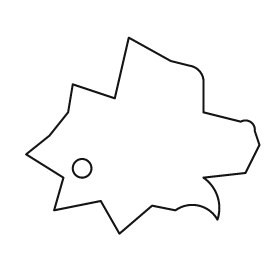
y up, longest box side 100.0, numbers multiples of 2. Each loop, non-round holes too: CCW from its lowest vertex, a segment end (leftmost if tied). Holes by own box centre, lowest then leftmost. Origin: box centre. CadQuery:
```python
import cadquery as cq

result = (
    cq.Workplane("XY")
    .moveTo(-10.0, -42.0)
    .lineTo(4.0, -30.0)
    .lineTo(14.0, -32.0)
    .threePointArc((24.0, -30.0), (32.0, -36.0))
    .threePointArc((32.0, -26.0), (26.0, -18.0))
    .lineTo(44.0, -16.0)
    .lineTo(50.0, -4.0)
    .lineTo(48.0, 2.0)
    .threePointArc((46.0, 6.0), (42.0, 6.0))
    .lineTo(26.0, 10.0)
    .lineTo(26.0, 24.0)
    .threePointArc((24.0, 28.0), (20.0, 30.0))
    .lineTo(12.0, 32.0)
    .lineTo(-6.0, 42.0)
    .lineTo(-12.0, 16.0)
    .lineTo(-30.0, 22.0)
    .lineTo(-32.0, 10.0)
    .lineTo(-40.0, 0.0)
    .lineTo(-50.0, -8.0)
    .lineTo(-34.0, -18.0)
    .lineTo(-38.0, -32.0)
    .lineTo(-18.0, -28.0)
    .close()
    .moveTo(-26.0, -14.0)
    .circle(4.0)
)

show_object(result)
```